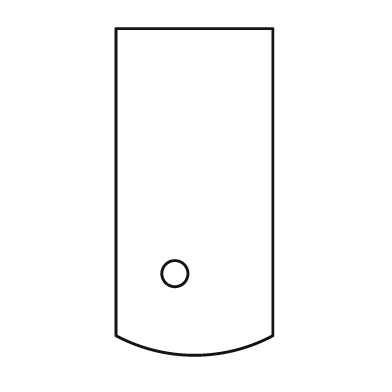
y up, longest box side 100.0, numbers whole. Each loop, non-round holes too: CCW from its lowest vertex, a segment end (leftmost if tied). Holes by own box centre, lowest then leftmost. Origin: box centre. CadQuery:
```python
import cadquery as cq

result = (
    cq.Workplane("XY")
    .moveTo(-24.0, -44.0)
    .threePointArc((0.0, -50.0), (24.0, -44.0))
    .lineTo(24.0, 50.0)
    .lineTo(-24.0, 50.0)
    .close()
    .moveTo(-6.0, -25.0)
    .circle(4.0)
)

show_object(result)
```